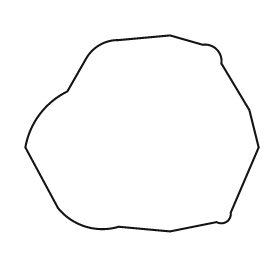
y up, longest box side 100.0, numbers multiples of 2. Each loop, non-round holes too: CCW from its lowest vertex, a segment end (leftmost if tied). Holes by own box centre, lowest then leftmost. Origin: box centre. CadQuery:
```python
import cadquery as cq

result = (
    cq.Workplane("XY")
    .moveTo(12.0, -42.0)
    .lineTo(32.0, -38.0)
    .threePointArc((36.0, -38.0), (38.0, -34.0))
    .lineTo(50.0, -6.0)
    .lineTo(46.0, 10.0)
    .lineTo(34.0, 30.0)
    .threePointArc((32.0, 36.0), (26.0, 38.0))
    .lineTo(12.0, 42.0)
    .lineTo(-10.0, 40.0)
    .threePointArc((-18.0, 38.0), (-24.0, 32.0))
    .lineTo(-32.0, 18.0)
    .threePointArc((-44.0, 8.0), (-50.0, -6.0))
    .lineTo(-36.0, -32.0)
    .threePointArc((-24.0, -40.0), (-10.0, -40.0))
    .close()
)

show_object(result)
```